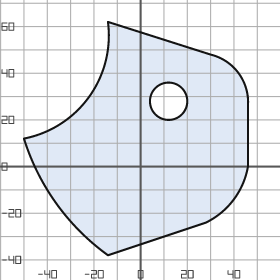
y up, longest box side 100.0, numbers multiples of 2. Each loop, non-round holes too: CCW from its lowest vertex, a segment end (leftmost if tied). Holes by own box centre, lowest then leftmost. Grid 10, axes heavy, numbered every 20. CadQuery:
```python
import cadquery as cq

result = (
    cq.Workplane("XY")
    .moveTo(-14.0, -38.0)
    .lineTo(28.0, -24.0)
    .threePointArc((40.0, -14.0), (46.0, 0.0))
    .lineTo(46.0, 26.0)
    .threePointArc((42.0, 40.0), (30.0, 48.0))
    .lineTo(-14.0, 62.0)
    .threePointArc((-22.0, 30.0), (-50.0, 12.0))
    .threePointArc((-36.0, -16.0), (-14.0, -38.0))
    .close()
    .moveTo(12.0, 28.0)
    .circle(8.0)
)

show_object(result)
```